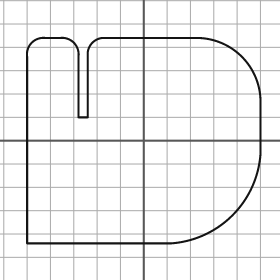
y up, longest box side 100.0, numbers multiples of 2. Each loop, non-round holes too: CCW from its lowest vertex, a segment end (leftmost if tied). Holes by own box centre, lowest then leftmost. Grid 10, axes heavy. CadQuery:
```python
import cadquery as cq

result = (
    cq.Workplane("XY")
    .moveTo(-50.0, -44.0)
    .lineTo(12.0, -44.0)
    .threePointArc((38.0, -32.0), (50.0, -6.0))
    .lineTo(50.0, 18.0)
    .threePointArc((42.0, 36.0), (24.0, 44.0))
    .lineTo(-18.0, 44.0)
    .threePointArc((-22.0, 42.0), (-24.0, 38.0))
    .lineTo(-24.0, 10.0)
    .lineTo(-28.0, 10.0)
    .lineTo(-28.0, 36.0)
    .threePointArc((-30.0, 42.0), (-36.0, 44.0))
    .lineTo(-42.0, 44.0)
    .threePointArc((-48.0, 42.0), (-50.0, 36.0))
    .close()
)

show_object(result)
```